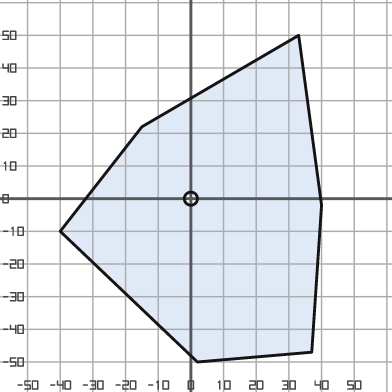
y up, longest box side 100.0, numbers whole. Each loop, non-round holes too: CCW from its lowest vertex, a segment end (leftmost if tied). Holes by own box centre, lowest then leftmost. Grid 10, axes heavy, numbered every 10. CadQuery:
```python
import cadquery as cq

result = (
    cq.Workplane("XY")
    .moveTo(2.0, -50.0)
    .lineTo(37.0, -47.0)
    .lineTo(40.0, -2.0)
    .lineTo(33.0, 50.0)
    .lineTo(-15.0, 22.0)
    .lineTo(-40.0, -10.0)
    .close()
    .moveTo(0.0, 0.0)
    .circle(2.0)
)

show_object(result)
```